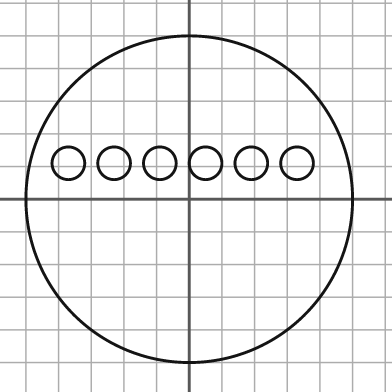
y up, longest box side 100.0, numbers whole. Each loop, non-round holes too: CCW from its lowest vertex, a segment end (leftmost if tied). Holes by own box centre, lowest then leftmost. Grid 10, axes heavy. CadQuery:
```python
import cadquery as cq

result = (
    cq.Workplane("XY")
    .moveTo(0.0, 0.0)
    .circle(50.0)
    .moveTo(-37.0, 11.0)
    .circle(5.0)
    .moveTo(-23.0, 11.0)
    .circle(5.0)
    .moveTo(-9.0, 11.0)
    .circle(5.0)
    .moveTo(5.0, 11.0)
    .circle(5.0)
    .moveTo(19.0, 11.0)
    .circle(5.0)
    .moveTo(33.0, 11.0)
    .circle(5.0)
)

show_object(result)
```